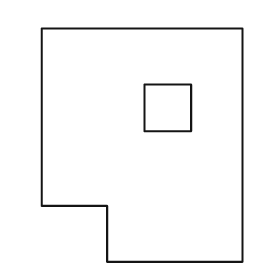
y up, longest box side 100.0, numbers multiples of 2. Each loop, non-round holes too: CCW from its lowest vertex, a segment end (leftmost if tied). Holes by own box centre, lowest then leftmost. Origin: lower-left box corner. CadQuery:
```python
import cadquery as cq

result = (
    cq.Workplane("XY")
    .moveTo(28.0, 0.0)
    .lineTo(86.0, 0.0)
    .lineTo(86.0, 100.0)
    .lineTo(0.0, 100.0)
    .lineTo(0.0, 24.0)
    .lineTo(28.0, 24.0)
    .close()
    .moveTo(44.0, 56.0)
    .lineTo(64.0, 56.0)
    .lineTo(64.0, 76.0)
    .lineTo(44.0, 76.0)
    .close()
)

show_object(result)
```